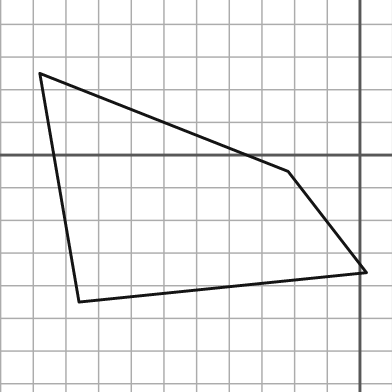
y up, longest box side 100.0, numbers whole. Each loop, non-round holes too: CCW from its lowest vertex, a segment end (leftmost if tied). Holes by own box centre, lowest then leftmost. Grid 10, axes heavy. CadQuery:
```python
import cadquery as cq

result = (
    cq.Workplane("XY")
    .moveTo(-86.0, -45.0)
    .lineTo(2.0, -36.0)
    .lineTo(-22.0, -5.0)
    .lineTo(-98.0, 25.0)
    .close()
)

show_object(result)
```